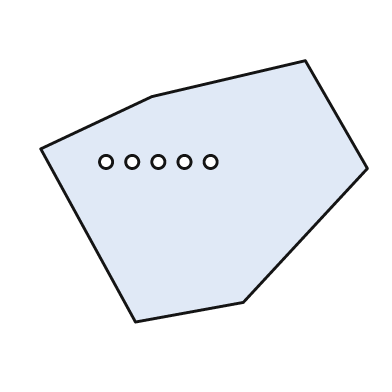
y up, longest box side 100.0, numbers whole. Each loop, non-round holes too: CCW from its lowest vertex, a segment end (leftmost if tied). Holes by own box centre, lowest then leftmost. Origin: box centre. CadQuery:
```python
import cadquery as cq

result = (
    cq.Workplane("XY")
    .moveTo(-21.0, -40.0)
    .lineTo(12.0, -34.0)
    .lineTo(50.0, 7.0)
    .lineTo(31.0, 40.0)
    .lineTo(-16.0, 29.0)
    .lineTo(-50.0, 13.0)
    .close()
    .moveTo(-30.0, 9.0)
    .circle(2.0)
    .moveTo(-22.0, 9.0)
    .circle(2.0)
    .moveTo(-14.0, 9.0)
    .circle(2.0)
    .moveTo(-6.0, 9.0)
    .circle(2.0)
    .moveTo(2.0, 9.0)
    .circle(2.0)
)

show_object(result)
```